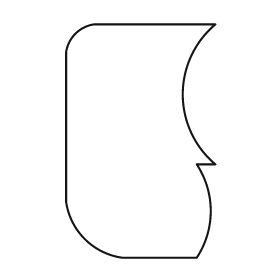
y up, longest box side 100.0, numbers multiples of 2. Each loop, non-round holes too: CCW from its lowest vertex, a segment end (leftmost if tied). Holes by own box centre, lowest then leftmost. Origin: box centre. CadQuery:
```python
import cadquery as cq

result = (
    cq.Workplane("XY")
    .moveTo(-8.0, -50.0)
    .lineTo(24.0, -50.0)
    .threePointArc((30.0, -30.0), (24.0, -10.0))
    .lineTo(32.0, -10.0)
    .threePointArc((18.0, 20.0), (32.0, 50.0))
    .lineTo(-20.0, 50.0)
    .threePointArc((-28.0, 46.0), (-32.0, 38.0))
    .lineTo(-32.0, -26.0)
    .threePointArc((-24.0, -42.0), (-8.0, -50.0))
    .close()
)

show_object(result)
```